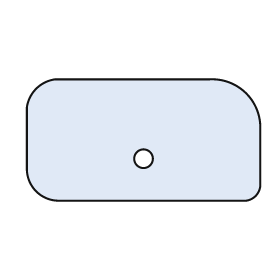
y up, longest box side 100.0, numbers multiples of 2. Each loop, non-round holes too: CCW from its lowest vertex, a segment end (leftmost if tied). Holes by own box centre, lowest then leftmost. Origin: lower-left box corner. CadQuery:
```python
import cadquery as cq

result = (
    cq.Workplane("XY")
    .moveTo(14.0, 0.0)
    .lineTo(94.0, 0.0)
    .threePointArc((98.0, 2.0), (100.0, 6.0))
    .lineTo(100.0, 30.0)
    .threePointArc((94.0, 46.0), (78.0, 52.0))
    .lineTo(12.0, 52.0)
    .threePointArc((4.0, 48.0), (0.0, 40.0))
    .lineTo(0.0, 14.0)
    .threePointArc((4.0, 4.0), (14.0, 0.0))
    .close()
    .moveTo(50.0, 18.0)
    .circle(4.0)
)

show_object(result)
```